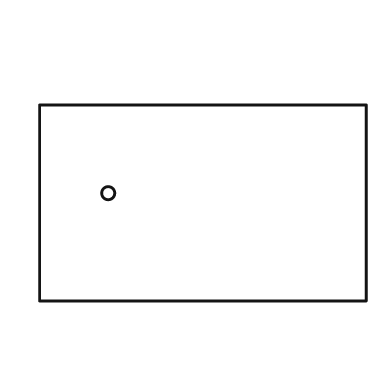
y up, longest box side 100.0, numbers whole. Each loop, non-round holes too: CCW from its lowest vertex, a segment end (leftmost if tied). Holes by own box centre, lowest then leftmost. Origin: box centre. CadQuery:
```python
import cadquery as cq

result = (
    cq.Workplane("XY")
    .moveTo(-50.0, -30.0)
    .lineTo(50.0, -30.0)
    .lineTo(50.0, 30.0)
    .lineTo(-50.0, 30.0)
    .close()
    .moveTo(-29.0, 3.0)
    .circle(2.0)
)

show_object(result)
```